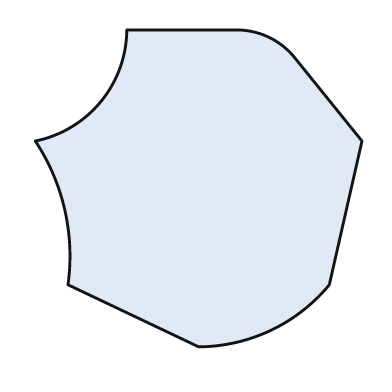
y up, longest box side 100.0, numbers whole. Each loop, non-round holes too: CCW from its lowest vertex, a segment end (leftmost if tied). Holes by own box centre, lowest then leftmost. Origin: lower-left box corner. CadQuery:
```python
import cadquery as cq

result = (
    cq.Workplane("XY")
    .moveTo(50.0, 0.0)
    .threePointArc((72.0, 5.0), (90.0, 19.0))
    .lineTo(100.0, 63.0)
    .lineTo(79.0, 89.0)
    .threePointArc((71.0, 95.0), (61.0, 97.0))
    .lineTo(28.0, 97.0)
    .threePointArc((20.0, 75.0), (0.0, 63.0))
    .threePointArc((9.0, 42.0), (10.0, 19.0))
    .close()
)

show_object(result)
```